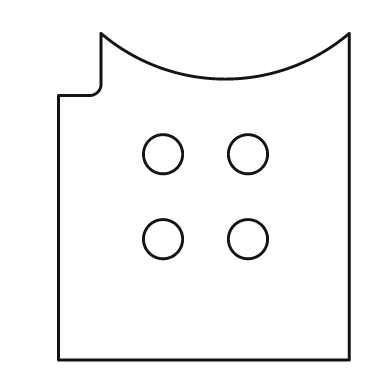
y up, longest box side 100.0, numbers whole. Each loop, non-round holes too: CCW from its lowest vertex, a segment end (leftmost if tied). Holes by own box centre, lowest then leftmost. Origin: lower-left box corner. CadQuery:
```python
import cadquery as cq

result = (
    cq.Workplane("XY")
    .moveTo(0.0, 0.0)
    .lineTo(89.0, 0.0)
    .lineTo(89.0, 100.0)
    .threePointArc((51.0, 86.0), (13.0, 100.0))
    .lineTo(13.0, 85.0)
    .threePointArc((12.0, 82.0), (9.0, 81.0))
    .lineTo(0.0, 81.0)
    .close()
    .moveTo(32.0, 37.0)
    .circle(6.0)
    .moveTo(58.0, 37.0)
    .circle(6.0)
    .moveTo(32.0, 63.0)
    .circle(6.0)
    .moveTo(58.0, 63.0)
    .circle(6.0)
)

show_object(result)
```